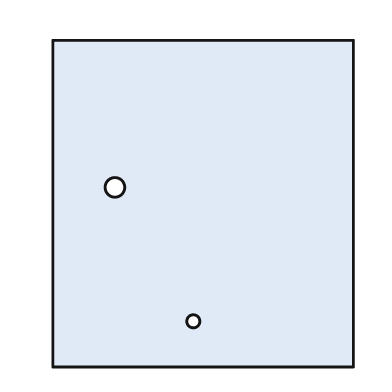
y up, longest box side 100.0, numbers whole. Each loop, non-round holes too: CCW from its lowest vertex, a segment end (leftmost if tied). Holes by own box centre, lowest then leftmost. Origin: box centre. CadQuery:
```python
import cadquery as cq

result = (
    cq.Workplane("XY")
    .moveTo(-46.0, -50.0)
    .lineTo(46.0, -50.0)
    .lineTo(46.0, 50.0)
    .lineTo(-46.0, 50.0)
    .close()
    .moveTo(-3.0, -36.0)
    .circle(2.0)
    .moveTo(-27.0, 5.0)
    .circle(3.0)
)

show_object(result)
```